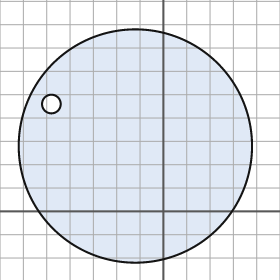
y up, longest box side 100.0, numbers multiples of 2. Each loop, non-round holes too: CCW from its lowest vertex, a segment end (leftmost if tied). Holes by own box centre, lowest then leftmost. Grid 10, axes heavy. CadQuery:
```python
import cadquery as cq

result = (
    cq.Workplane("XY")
    .moveTo(-12.0, 28.0)
    .circle(50.0)
    .moveTo(-48.0, 46.0)
    .circle(4.0)
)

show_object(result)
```